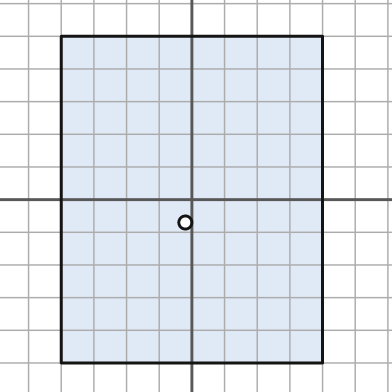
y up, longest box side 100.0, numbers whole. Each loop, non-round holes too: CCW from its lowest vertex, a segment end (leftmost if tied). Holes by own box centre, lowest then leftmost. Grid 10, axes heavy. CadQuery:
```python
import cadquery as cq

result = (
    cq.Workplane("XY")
    .moveTo(-40.0, -50.0)
    .lineTo(40.0, -50.0)
    .lineTo(40.0, 50.0)
    .lineTo(-40.0, 50.0)
    .close()
    .moveTo(-2.0, -7.0)
    .circle(2.0)
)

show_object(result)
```